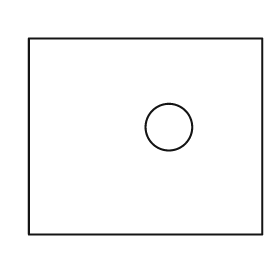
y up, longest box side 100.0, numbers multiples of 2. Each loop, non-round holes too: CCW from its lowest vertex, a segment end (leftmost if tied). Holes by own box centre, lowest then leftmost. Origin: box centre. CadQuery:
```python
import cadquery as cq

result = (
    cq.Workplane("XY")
    .moveTo(-50.0, -42.0)
    .lineTo(50.0, -42.0)
    .lineTo(50.0, 42.0)
    .lineTo(-50.0, 42.0)
    .close()
    .moveTo(10.0, 4.0)
    .circle(10.0)
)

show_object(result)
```